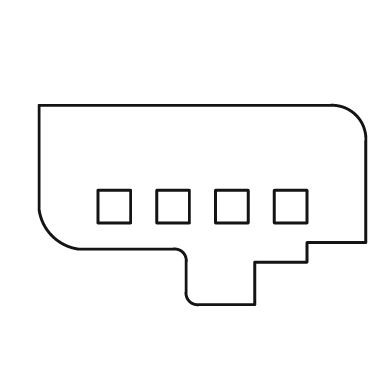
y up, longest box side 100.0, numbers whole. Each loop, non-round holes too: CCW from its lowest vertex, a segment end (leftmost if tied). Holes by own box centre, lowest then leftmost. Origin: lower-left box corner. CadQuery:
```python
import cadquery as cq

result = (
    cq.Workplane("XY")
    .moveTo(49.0, 0.0)
    .lineTo(66.0, 0.0)
    .lineTo(66.0, 13.0)
    .lineTo(82.0, 13.0)
    .lineTo(82.0, 19.0)
    .lineTo(100.0, 19.0)
    .lineTo(100.0, 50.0)
    .threePointArc((97.0, 58.0), (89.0, 61.0))
    .lineTo(0.0, 61.0)
    .lineTo(0.0, 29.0)
    .threePointArc((4.0, 21.0), (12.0, 17.0))
    .lineTo(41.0, 17.0)
    .threePointArc((44.0, 16.0), (45.0, 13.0))
    .lineTo(45.0, 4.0)
    .threePointArc((46.0, 1.0), (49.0, 0.0))
    .close()
    .moveTo(18.0, 25.0)
    .lineTo(28.0, 25.0)
    .lineTo(28.0, 35.0)
    .lineTo(18.0, 35.0)
    .close()
    .moveTo(36.0, 25.0)
    .lineTo(46.0, 25.0)
    .lineTo(46.0, 35.0)
    .lineTo(36.0, 35.0)
    .close()
    .moveTo(54.0, 25.0)
    .lineTo(64.0, 25.0)
    .lineTo(64.0, 35.0)
    .lineTo(54.0, 35.0)
    .close()
    .moveTo(72.0, 25.0)
    .lineTo(82.0, 25.0)
    .lineTo(82.0, 35.0)
    .lineTo(72.0, 35.0)
    .close()
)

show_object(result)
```